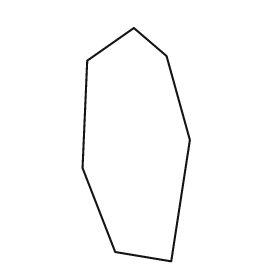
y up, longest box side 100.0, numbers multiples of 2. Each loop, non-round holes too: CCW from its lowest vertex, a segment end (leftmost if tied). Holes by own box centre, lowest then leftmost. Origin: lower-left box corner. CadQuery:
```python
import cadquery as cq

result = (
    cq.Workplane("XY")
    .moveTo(38.0, 0.0)
    .lineTo(46.0, 52.0)
    .lineTo(36.0, 88.0)
    .lineTo(22.0, 100.0)
    .lineTo(2.0, 86.0)
    .lineTo(0.0, 40.0)
    .lineTo(14.0, 4.0)
    .close()
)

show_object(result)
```